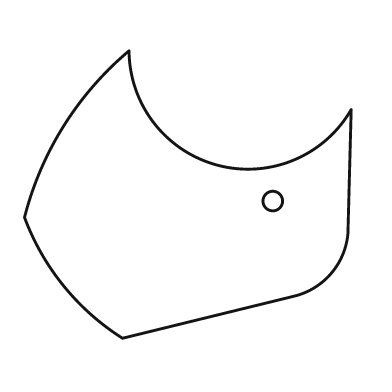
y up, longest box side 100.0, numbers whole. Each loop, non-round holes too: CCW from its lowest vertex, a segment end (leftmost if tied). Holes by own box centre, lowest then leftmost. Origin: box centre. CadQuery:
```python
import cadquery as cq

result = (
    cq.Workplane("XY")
    .moveTo(-20.0, -44.0)
    .lineTo(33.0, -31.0)
    .threePointArc((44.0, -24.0), (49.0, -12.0))
    .lineTo(50.0, 26.0)
    .threePointArc((9.0, 9.0), (-18.0, 44.0))
    .threePointArc((-38.0, 21.0), (-50.0, -7.0))
    .threePointArc((-38.0, -28.0), (-20.0, -44.0))
    .close()
    .moveTo(26.0, -2.0)
    .circle(3.0)
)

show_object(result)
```